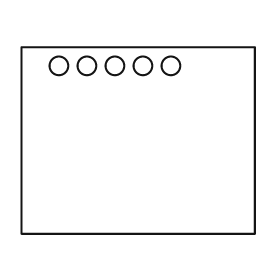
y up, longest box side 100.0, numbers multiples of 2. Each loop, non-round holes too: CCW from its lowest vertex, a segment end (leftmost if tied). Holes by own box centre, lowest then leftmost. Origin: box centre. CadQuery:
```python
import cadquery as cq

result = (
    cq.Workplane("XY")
    .moveTo(-50.0, -40.0)
    .lineTo(50.0, -40.0)
    .lineTo(50.0, 40.0)
    .lineTo(-50.0, 40.0)
    .close()
    .moveTo(-34.0, 32.0)
    .circle(4.0)
    .moveTo(-22.0, 32.0)
    .circle(4.0)
    .moveTo(-10.0, 32.0)
    .circle(4.0)
    .moveTo(2.0, 32.0)
    .circle(4.0)
    .moveTo(14.0, 32.0)
    .circle(4.0)
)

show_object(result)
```